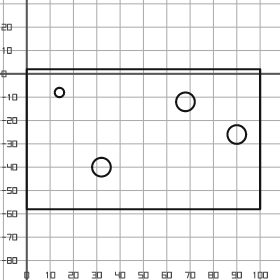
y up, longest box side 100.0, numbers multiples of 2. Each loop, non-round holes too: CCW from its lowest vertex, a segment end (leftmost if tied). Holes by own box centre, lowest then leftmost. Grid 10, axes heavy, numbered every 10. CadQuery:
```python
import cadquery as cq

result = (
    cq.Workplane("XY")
    .moveTo(0.0, -58.0)
    .lineTo(100.0, -58.0)
    .lineTo(100.0, 2.0)
    .lineTo(0.0, 2.0)
    .close()
    .moveTo(32.0, -40.0)
    .circle(4.0)
    .moveTo(90.0, -26.0)
    .circle(4.0)
    .moveTo(68.0, -12.0)
    .circle(4.0)
    .moveTo(14.0, -8.0)
    .circle(2.0)
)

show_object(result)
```